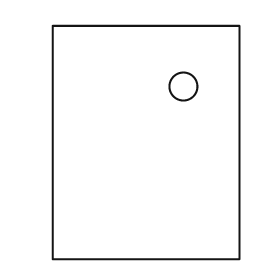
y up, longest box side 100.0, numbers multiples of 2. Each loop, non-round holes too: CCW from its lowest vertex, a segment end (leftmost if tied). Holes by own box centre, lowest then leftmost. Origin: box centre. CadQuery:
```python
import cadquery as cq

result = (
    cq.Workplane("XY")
    .moveTo(-40.0, -50.0)
    .lineTo(40.0, -50.0)
    .lineTo(40.0, 50.0)
    .lineTo(-40.0, 50.0)
    .close()
    .moveTo(16.0, 24.0)
    .circle(6.0)
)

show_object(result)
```